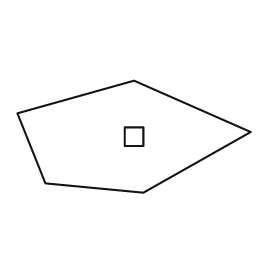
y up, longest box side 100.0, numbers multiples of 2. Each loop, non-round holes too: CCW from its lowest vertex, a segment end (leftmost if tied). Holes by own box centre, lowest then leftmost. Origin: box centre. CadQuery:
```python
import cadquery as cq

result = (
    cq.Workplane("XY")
    .moveTo(4.0, -24.0)
    .lineTo(50.0, 2.0)
    .lineTo(0.0, 24.0)
    .lineTo(-50.0, 10.0)
    .lineTo(-38.0, -20.0)
    .close()
    .moveTo(-4.0, -4.0)
    .lineTo(4.0, -4.0)
    .lineTo(4.0, 4.0)
    .lineTo(-4.0, 4.0)
    .close()
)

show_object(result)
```